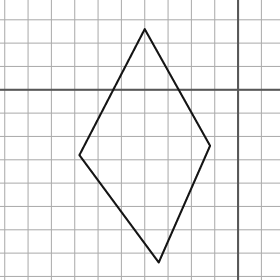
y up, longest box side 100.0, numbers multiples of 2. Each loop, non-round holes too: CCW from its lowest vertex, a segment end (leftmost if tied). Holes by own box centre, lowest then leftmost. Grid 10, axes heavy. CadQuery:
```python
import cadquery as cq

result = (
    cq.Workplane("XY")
    .moveTo(-34.0, -74.0)
    .lineTo(-12.0, -24.0)
    .lineTo(-40.0, 26.0)
    .lineTo(-68.0, -28.0)
    .close()
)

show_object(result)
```